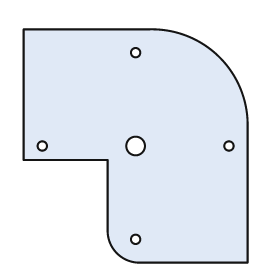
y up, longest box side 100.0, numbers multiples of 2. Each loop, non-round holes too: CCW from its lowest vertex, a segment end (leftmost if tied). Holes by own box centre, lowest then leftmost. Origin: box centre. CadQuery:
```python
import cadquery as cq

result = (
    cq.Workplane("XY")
    .moveTo(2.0, -50.0)
    .lineTo(48.0, -50.0)
    .lineTo(48.0, 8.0)
    .threePointArc((36.0, 38.0), (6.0, 50.0))
    .lineTo(-48.0, 50.0)
    .lineTo(-48.0, -6.0)
    .lineTo(-12.0, -6.0)
    .lineTo(-12.0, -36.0)
    .threePointArc((-8.0, -46.0), (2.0, -50.0))
    .close()
    .moveTo(0.0, -40.0)
    .circle(2.0)
    .moveTo(-40.0, 0.0)
    .circle(2.0)
    .moveTo(0.0, 0.0)
    .circle(4.0)
    .moveTo(40.0, 0.0)
    .circle(2.0)
    .moveTo(0.0, 40.0)
    .circle(2.0)
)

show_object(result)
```